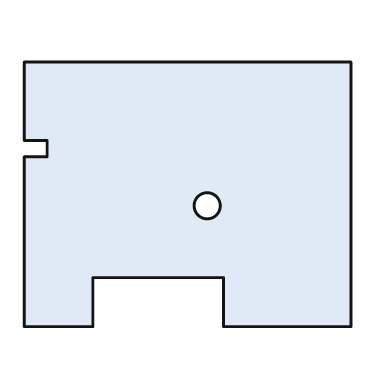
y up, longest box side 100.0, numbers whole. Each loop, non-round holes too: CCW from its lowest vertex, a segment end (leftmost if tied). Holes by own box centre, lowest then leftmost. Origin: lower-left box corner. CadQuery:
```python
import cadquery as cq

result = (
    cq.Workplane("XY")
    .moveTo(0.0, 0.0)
    .lineTo(21.0, 0.0)
    .lineTo(21.0, 15.0)
    .lineTo(61.0, 15.0)
    .lineTo(61.0, 0.0)
    .lineTo(100.0, 0.0)
    .lineTo(100.0, 81.0)
    .lineTo(0.0, 81.0)
    .lineTo(0.0, 57.0)
    .lineTo(7.0, 57.0)
    .lineTo(7.0, 52.0)
    .lineTo(0.0, 52.0)
    .close()
    .moveTo(56.0, 37.0)
    .circle(4.0)
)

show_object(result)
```